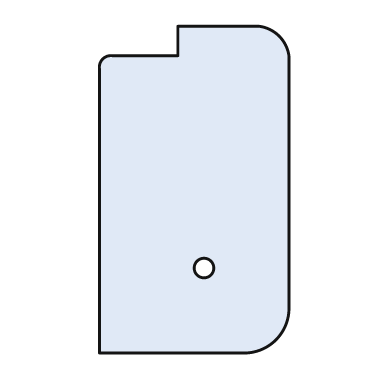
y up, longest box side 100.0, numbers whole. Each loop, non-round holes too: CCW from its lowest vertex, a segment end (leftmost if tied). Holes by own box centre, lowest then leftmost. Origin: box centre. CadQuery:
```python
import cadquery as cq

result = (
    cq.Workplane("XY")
    .moveTo(-29.0, -50.0)
    .lineTo(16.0, -50.0)
    .threePointArc((25.0, -46.0), (29.0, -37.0))
    .lineTo(29.0, 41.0)
    .threePointArc((26.0, 47.0), (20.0, 50.0))
    .lineTo(-5.0, 50.0)
    .lineTo(-5.0, 41.0)
    .lineTo(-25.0, 41.0)
    .threePointArc((-28.0, 40.0), (-29.0, 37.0))
    .close()
    .moveTo(3.0, -24.0)
    .circle(3.0)
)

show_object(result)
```